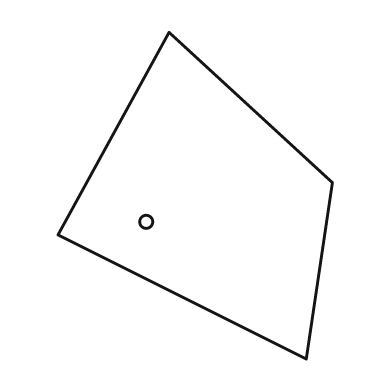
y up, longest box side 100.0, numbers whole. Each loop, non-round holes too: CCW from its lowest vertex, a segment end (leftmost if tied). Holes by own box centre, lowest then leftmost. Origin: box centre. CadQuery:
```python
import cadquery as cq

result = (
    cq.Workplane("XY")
    .moveTo(34.0, -50.0)
    .lineTo(42.0, 4.0)
    .lineTo(-8.0, 50.0)
    .lineTo(-42.0, -12.0)
    .close()
    .moveTo(-15.0, -8.0)
    .circle(2.0)
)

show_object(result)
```